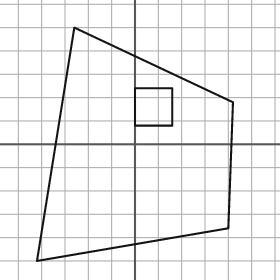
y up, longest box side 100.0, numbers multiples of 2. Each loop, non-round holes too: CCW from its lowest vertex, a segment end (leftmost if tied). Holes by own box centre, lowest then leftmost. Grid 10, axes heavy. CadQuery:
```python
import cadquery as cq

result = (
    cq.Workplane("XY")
    .moveTo(-42.0, -50.0)
    .lineTo(40.0, -36.0)
    .lineTo(42.0, 18.0)
    .lineTo(-26.0, 50.0)
    .close()
    .moveTo(0.0, 8.0)
    .lineTo(16.0, 8.0)
    .lineTo(16.0, 24.0)
    .lineTo(0.0, 24.0)
    .close()
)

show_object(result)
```